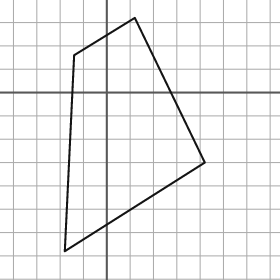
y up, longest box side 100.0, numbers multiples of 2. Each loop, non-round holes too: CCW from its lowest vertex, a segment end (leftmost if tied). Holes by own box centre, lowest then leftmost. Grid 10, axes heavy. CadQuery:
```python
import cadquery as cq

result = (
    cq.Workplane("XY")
    .moveTo(-18.0, -68.0)
    .lineTo(42.0, -30.0)
    .lineTo(12.0, 32.0)
    .lineTo(-14.0, 16.0)
    .close()
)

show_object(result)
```